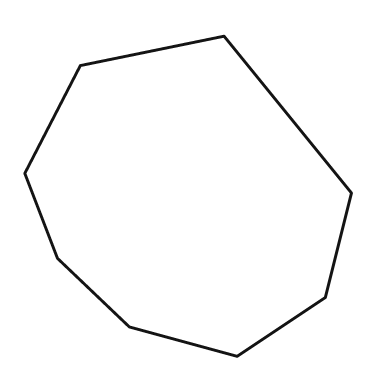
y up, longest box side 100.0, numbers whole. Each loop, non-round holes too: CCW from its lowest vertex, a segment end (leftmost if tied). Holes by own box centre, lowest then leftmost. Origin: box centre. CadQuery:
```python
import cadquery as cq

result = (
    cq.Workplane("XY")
    .moveTo(15.0, -49.0)
    .lineTo(42.0, -31.0)
    .lineTo(50.0, 1.0)
    .lineTo(11.0, 49.0)
    .lineTo(-33.0, 40.0)
    .lineTo(-50.0, 7.0)
    .lineTo(-40.0, -19.0)
    .lineTo(-18.0, -40.0)
    .close()
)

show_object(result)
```